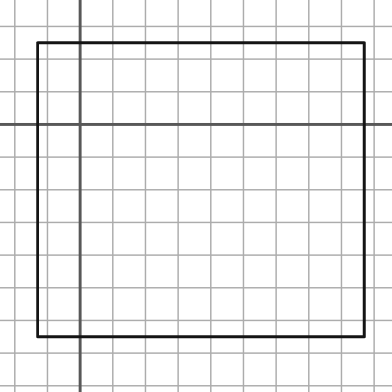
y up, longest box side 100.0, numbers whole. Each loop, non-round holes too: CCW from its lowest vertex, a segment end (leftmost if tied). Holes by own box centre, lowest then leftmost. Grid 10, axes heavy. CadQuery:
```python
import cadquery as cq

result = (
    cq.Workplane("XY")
    .moveTo(-13.0, -65.0)
    .lineTo(87.0, -65.0)
    .lineTo(87.0, 25.0)
    .lineTo(-13.0, 25.0)
    .close()
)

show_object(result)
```